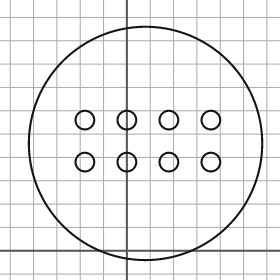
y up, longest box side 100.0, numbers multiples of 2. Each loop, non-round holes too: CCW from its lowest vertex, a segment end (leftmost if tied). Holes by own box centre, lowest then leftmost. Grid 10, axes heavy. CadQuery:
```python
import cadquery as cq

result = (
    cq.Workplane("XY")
    .moveTo(8.0, 46.0)
    .circle(50.0)
    .moveTo(-18.0, 38.0)
    .circle(4.0)
    .moveTo(0.0, 38.0)
    .circle(4.0)
    .moveTo(18.0, 38.0)
    .circle(4.0)
    .moveTo(36.0, 38.0)
    .circle(4.0)
    .moveTo(-18.0, 56.0)
    .circle(4.0)
    .moveTo(0.0, 56.0)
    .circle(4.0)
    .moveTo(18.0, 56.0)
    .circle(4.0)
    .moveTo(36.0, 56.0)
    .circle(4.0)
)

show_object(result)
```